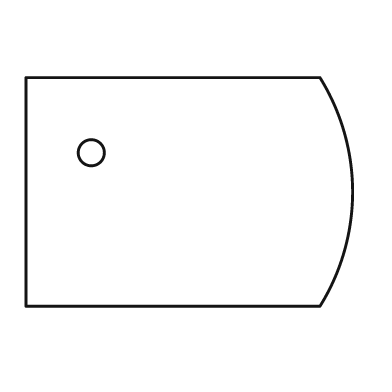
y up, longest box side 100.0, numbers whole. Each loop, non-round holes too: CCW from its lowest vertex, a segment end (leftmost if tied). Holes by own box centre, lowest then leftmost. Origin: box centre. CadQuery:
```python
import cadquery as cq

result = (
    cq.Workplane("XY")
    .moveTo(-50.0, -35.0)
    .lineTo(40.0, -35.0)
    .threePointArc((50.0, 0.0), (40.0, 35.0))
    .lineTo(-50.0, 35.0)
    .close()
    .moveTo(-30.0, 12.0)
    .circle(4.0)
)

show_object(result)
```